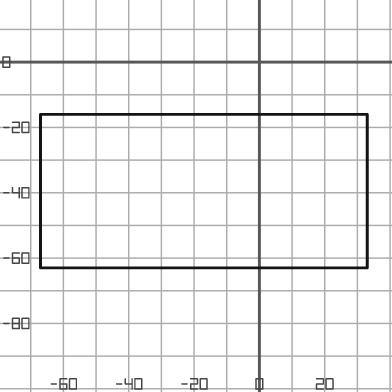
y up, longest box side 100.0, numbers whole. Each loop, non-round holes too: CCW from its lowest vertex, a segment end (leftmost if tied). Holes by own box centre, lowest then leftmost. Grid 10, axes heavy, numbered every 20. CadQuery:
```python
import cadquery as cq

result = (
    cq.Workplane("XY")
    .moveTo(-67.0, -63.0)
    .lineTo(33.0, -63.0)
    .lineTo(33.0, -16.0)
    .lineTo(-67.0, -16.0)
    .close()
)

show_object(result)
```